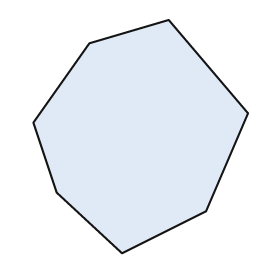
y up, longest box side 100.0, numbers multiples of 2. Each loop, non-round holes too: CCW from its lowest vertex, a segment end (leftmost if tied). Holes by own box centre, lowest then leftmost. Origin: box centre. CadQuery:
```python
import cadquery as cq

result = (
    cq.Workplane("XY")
    .moveTo(-8.0, -50.0)
    .lineTo(28.0, -32.0)
    .lineTo(46.0, 10.0)
    .lineTo(12.0, 50.0)
    .lineTo(-22.0, 40.0)
    .lineTo(-46.0, 6.0)
    .lineTo(-36.0, -24.0)
    .close()
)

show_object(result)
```